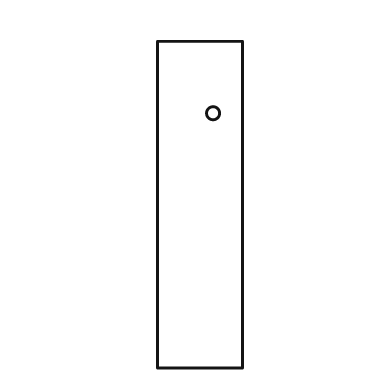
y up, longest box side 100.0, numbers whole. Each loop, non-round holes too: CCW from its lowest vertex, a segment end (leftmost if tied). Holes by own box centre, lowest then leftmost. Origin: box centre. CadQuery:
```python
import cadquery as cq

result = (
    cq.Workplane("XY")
    .moveTo(-13.0, -50.0)
    .lineTo(13.0, -50.0)
    .lineTo(13.0, 50.0)
    .lineTo(-13.0, 50.0)
    .close()
    .moveTo(4.0, 28.0)
    .circle(2.0)
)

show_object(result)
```